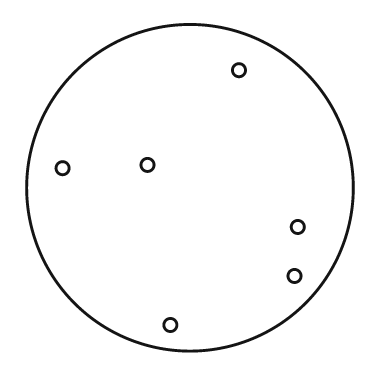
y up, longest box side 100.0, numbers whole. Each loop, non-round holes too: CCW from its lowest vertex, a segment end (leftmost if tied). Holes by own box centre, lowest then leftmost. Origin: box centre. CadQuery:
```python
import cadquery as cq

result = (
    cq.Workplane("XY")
    .moveTo(0.0, 0.0)
    .circle(50.0)
    .moveTo(-6.0, -42.0)
    .circle(2.0)
    .moveTo(32.0, -27.0)
    .circle(2.0)
    .moveTo(33.0, -12.0)
    .circle(2.0)
    .moveTo(-39.0, 6.0)
    .circle(2.0)
    .moveTo(-13.0, 7.0)
    .circle(2.0)
    .moveTo(15.0, 36.0)
    .circle(2.0)
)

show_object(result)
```